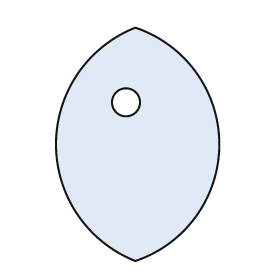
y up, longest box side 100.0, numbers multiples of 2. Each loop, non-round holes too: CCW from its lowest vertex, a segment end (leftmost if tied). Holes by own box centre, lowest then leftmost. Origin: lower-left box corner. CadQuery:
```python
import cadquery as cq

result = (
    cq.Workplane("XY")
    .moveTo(34.0, 0.0)
    .threePointArc((70.0, 50.0), (34.0, 100.0))
    .threePointArc((0.0, 50.0), (34.0, 0.0))
    .close()
    .moveTo(30.0, 68.0)
    .circle(6.0)
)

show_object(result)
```